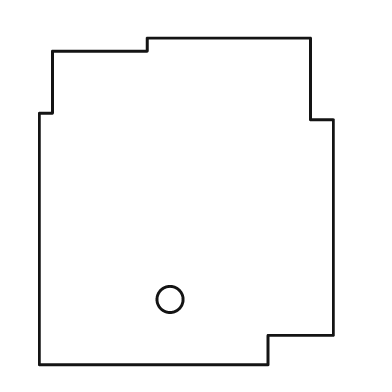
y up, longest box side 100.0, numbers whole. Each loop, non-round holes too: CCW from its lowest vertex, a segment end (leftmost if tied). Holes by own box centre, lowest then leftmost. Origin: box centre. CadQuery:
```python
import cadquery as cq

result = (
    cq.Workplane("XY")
    .moveTo(-45.0, -50.0)
    .lineTo(25.0, -50.0)
    .lineTo(25.0, -41.0)
    .lineTo(45.0, -41.0)
    .lineTo(45.0, 25.0)
    .lineTo(38.0, 25.0)
    .lineTo(38.0, 50.0)
    .lineTo(-12.0, 50.0)
    .lineTo(-12.0, 46.0)
    .lineTo(-41.0, 46.0)
    .lineTo(-41.0, 27.0)
    .lineTo(-45.0, 27.0)
    .close()
    .moveTo(-5.0, -30.0)
    .circle(4.0)
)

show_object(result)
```